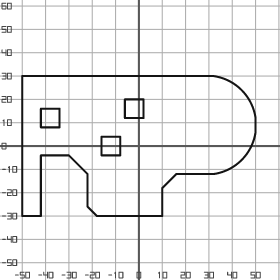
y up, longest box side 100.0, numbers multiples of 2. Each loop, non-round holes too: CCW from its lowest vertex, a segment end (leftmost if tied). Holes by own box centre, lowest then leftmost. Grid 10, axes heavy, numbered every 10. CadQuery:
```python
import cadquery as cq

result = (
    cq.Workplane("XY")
    .moveTo(-50.0, -30.0)
    .lineTo(-42.0, -30.0)
    .lineTo(-42.0, -4.0)
    .lineTo(-30.0, -4.0)
    .lineTo(-22.0, -12.0)
    .lineTo(-22.0, -26.0)
    .lineTo(-18.0, -30.0)
    .lineTo(10.0, -30.0)
    .lineTo(10.0, -18.0)
    .lineTo(16.0, -12.0)
    .lineTo(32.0, -12.0)
    .threePointArc((44.0, -6.0), (50.0, 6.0))
    .lineTo(50.0, 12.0)
    .threePointArc((44.0, 24.0), (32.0, 30.0))
    .lineTo(-50.0, 30.0)
    .close()
    .moveTo(-16.0, -4.0)
    .lineTo(-8.0, -4.0)
    .lineTo(-8.0, 4.0)
    .lineTo(-16.0, 4.0)
    .close()
    .moveTo(-42.0, 8.0)
    .lineTo(-34.0, 8.0)
    .lineTo(-34.0, 16.0)
    .lineTo(-42.0, 16.0)
    .close()
    .moveTo(-6.0, 12.0)
    .lineTo(2.0, 12.0)
    .lineTo(2.0, 20.0)
    .lineTo(-6.0, 20.0)
    .close()
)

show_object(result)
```